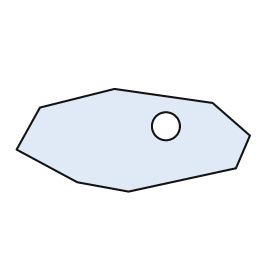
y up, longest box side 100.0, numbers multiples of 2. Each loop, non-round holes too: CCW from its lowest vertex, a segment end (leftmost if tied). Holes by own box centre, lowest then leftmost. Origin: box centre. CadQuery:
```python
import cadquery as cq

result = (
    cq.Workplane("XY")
    .moveTo(-2.0, -22.0)
    .lineTo(44.0, -12.0)
    .lineTo(50.0, 2.0)
    .lineTo(34.0, 16.0)
    .lineTo(-8.0, 22.0)
    .lineTo(-40.0, 14.0)
    .lineTo(-50.0, -4.0)
    .lineTo(-24.0, -18.0)
    .close()
    .moveTo(14.0, 6.0)
    .circle(6.0)
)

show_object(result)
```